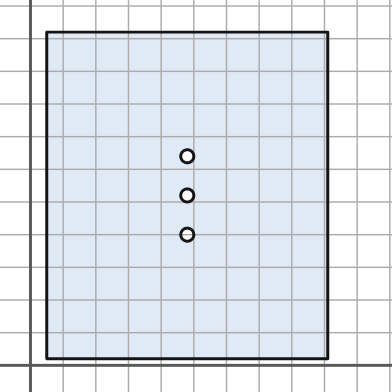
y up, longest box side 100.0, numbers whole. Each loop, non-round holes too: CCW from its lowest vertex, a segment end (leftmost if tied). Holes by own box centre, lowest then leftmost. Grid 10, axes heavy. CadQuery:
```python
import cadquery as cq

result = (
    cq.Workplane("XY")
    .moveTo(5.0, 2.0)
    .lineTo(91.0, 2.0)
    .lineTo(91.0, 102.0)
    .lineTo(5.0, 102.0)
    .close()
    .moveTo(48.0, 40.0)
    .circle(2.0)
    .moveTo(48.0, 52.0)
    .circle(2.0)
    .moveTo(48.0, 64.0)
    .circle(2.0)
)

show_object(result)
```